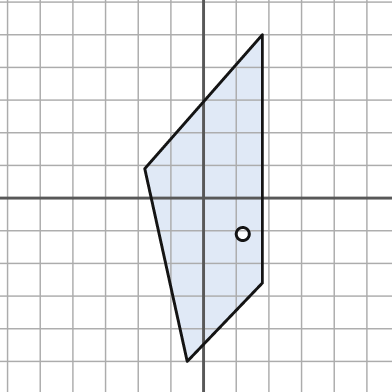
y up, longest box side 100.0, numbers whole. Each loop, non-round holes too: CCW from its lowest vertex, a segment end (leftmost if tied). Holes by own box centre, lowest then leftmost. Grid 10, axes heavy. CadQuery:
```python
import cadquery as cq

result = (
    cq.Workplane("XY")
    .moveTo(-5.0, -50.0)
    .lineTo(18.0, -26.0)
    .lineTo(18.0, 50.0)
    .lineTo(-18.0, 9.0)
    .close()
    .moveTo(12.0, -11.0)
    .circle(2.0)
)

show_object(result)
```